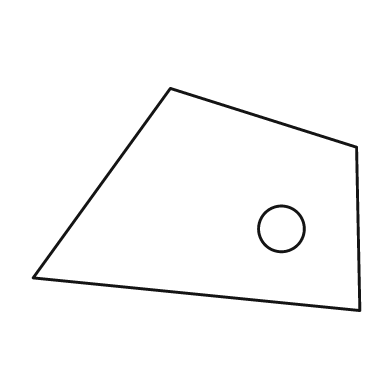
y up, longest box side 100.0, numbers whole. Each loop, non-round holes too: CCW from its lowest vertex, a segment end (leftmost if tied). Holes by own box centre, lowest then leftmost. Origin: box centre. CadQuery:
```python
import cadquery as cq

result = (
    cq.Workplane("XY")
    .moveTo(50.0, -34.0)
    .lineTo(49.0, 16.0)
    .lineTo(-8.0, 34.0)
    .lineTo(-50.0, -24.0)
    .close()
    .moveTo(26.0, -9.0)
    .circle(7.0)
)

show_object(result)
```